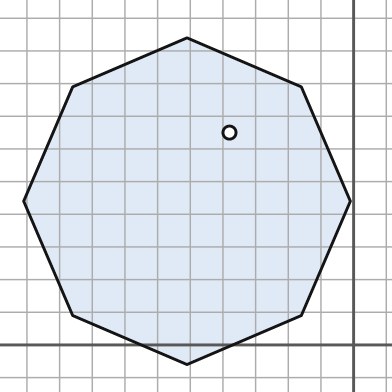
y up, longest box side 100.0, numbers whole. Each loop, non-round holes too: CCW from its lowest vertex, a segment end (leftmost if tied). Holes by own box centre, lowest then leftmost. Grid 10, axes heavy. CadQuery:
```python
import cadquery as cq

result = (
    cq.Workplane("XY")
    .moveTo(-51.0, -6.0)
    .lineTo(-16.0, 9.0)
    .lineTo(-1.0, 44.0)
    .lineTo(-16.0, 79.0)
    .lineTo(-51.0, 94.0)
    .lineTo(-86.0, 79.0)
    .lineTo(-101.0, 44.0)
    .lineTo(-86.0, 9.0)
    .close()
    .moveTo(-38.0, 65.0)
    .circle(2.0)
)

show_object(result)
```